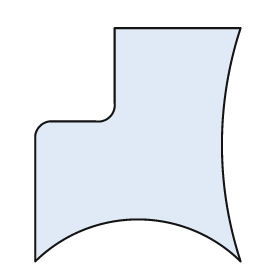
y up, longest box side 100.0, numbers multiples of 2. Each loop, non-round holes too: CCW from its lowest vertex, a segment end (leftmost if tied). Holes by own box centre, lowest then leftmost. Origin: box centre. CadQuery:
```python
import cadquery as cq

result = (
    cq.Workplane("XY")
    .moveTo(-44.0, -50.0)
    .threePointArc((0.0, -32.0), (44.0, -50.0))
    .threePointArc((36.0, 0.0), (44.0, 50.0))
    .lineTo(-10.0, 50.0)
    .lineTo(-10.0, 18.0)
    .threePointArc((-12.0, 12.0), (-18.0, 10.0))
    .lineTo(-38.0, 10.0)
    .threePointArc((-42.0, 8.0), (-44.0, 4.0))
    .close()
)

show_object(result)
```